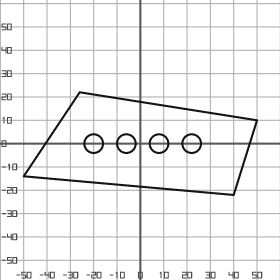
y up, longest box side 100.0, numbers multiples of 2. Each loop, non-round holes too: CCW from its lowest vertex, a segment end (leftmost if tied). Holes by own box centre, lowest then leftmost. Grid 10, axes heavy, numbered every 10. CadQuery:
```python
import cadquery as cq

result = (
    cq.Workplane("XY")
    .moveTo(40.0, -22.0)
    .lineTo(50.0, 10.0)
    .lineTo(-26.0, 22.0)
    .lineTo(-50.0, -14.0)
    .close()
    .moveTo(-20.0, 0.0)
    .circle(4.0)
    .moveTo(-6.0, 0.0)
    .circle(4.0)
    .moveTo(8.0, 0.0)
    .circle(4.0)
    .moveTo(22.0, 0.0)
    .circle(4.0)
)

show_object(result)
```